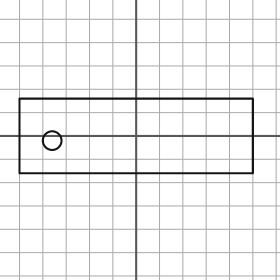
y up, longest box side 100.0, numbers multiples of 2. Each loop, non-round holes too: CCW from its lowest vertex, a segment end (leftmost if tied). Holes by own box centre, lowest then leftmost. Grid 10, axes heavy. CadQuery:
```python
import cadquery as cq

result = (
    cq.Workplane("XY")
    .moveTo(-50.0, -16.0)
    .lineTo(50.0, -16.0)
    .lineTo(50.0, 16.0)
    .lineTo(-50.0, 16.0)
    .close()
    .moveTo(-36.0, -2.0)
    .circle(4.0)
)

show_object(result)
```